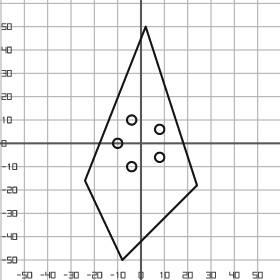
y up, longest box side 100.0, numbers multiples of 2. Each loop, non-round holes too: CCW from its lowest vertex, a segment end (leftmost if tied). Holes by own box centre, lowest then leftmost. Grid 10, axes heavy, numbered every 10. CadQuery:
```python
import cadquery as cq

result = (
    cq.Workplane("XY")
    .moveTo(-8.0, -50.0)
    .lineTo(24.0, -18.0)
    .lineTo(2.0, 50.0)
    .lineTo(-24.0, -16.0)
    .close()
    .moveTo(-4.0, -10.0)
    .circle(2.0)
    .moveTo(8.0, -6.0)
    .circle(2.0)
    .moveTo(-10.0, 0.0)
    .circle(2.0)
    .moveTo(8.0, 6.0)
    .circle(2.0)
    .moveTo(-4.0, 10.0)
    .circle(2.0)
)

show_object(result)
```